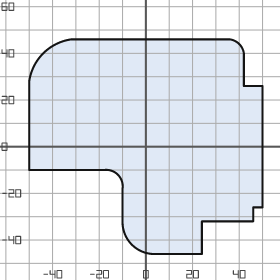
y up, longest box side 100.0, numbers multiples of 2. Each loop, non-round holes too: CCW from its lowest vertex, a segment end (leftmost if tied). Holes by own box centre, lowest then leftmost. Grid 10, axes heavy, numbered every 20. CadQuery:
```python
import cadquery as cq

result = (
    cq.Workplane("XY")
    .moveTo(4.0, -46.0)
    .lineTo(24.0, -46.0)
    .lineTo(24.0, -32.0)
    .lineTo(46.0, -32.0)
    .lineTo(46.0, -26.0)
    .lineTo(50.0, -26.0)
    .lineTo(50.0, 26.0)
    .lineTo(42.0, 26.0)
    .lineTo(42.0, 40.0)
    .threePointArc((40.0, 44.0), (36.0, 46.0))
    .lineTo(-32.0, 46.0)
    .threePointArc((-44.0, 40.0), (-50.0, 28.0))
    .lineTo(-50.0, -10.0)
    .lineTo(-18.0, -10.0)
    .threePointArc((-12.0, -12.0), (-10.0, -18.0))
    .lineTo(-10.0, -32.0)
    .threePointArc((-6.0, -42.0), (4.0, -46.0))
    .close()
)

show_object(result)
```